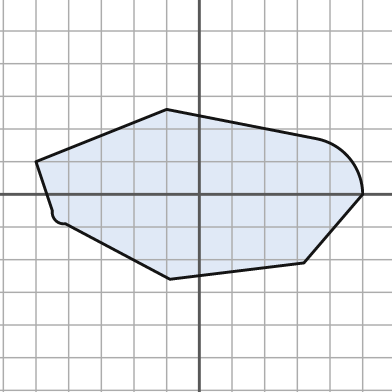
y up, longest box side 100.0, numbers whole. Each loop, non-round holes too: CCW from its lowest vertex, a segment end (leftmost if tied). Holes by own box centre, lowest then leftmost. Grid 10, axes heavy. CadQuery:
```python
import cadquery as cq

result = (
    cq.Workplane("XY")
    .moveTo(-9.0, -26.0)
    .lineTo(32.0, -21.0)
    .lineTo(50.0, 0.0)
    .threePointArc((46.0, 11.0), (36.0, 17.0))
    .lineTo(-10.0, 26.0)
    .lineTo(-50.0, 10.0)
    .lineTo(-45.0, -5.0)
    .threePointArc((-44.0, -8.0), (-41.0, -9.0))
    .close()
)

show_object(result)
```